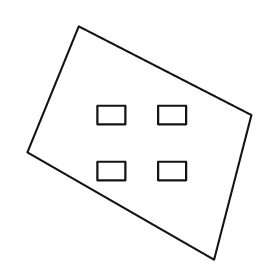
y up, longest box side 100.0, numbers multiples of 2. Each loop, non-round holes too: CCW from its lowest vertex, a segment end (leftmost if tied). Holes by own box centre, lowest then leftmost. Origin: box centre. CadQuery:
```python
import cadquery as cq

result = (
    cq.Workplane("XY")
    .moveTo(32.0, -50.0)
    .lineTo(48.0, 12.0)
    .lineTo(-26.0, 50.0)
    .lineTo(-48.0, -4.0)
    .close()
    .moveTo(-18.0, -16.0)
    .lineTo(-6.0, -16.0)
    .lineTo(-6.0, -8.0)
    .lineTo(-18.0, -8.0)
    .close()
    .moveTo(8.0, -16.0)
    .lineTo(20.0, -16.0)
    .lineTo(20.0, -8.0)
    .lineTo(8.0, -8.0)
    .close()
    .moveTo(-18.0, 8.0)
    .lineTo(-6.0, 8.0)
    .lineTo(-6.0, 16.0)
    .lineTo(-18.0, 16.0)
    .close()
    .moveTo(8.0, 8.0)
    .lineTo(20.0, 8.0)
    .lineTo(20.0, 16.0)
    .lineTo(8.0, 16.0)
    .close()
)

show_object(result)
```